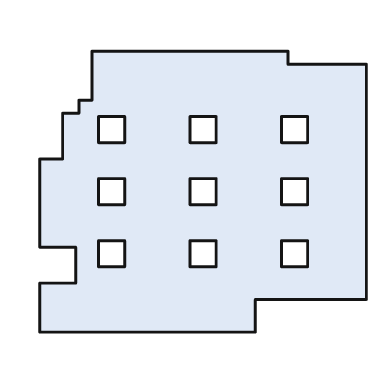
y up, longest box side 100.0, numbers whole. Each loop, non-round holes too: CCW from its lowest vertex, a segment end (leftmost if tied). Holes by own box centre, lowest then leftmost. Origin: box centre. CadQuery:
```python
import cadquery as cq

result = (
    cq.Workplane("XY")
    .moveTo(-50.0, -43.0)
    .lineTo(16.0, -43.0)
    .lineTo(16.0, -33.0)
    .lineTo(50.0, -33.0)
    .lineTo(50.0, 39.0)
    .lineTo(26.0, 39.0)
    .lineTo(26.0, 43.0)
    .lineTo(-34.0, 43.0)
    .lineTo(-34.0, 28.0)
    .lineTo(-38.0, 28.0)
    .lineTo(-38.0, 24.0)
    .lineTo(-43.0, 24.0)
    .lineTo(-43.0, 10.0)
    .lineTo(-50.0, 10.0)
    .lineTo(-50.0, -17.0)
    .lineTo(-39.0, -17.0)
    .lineTo(-39.0, -28.0)
    .lineTo(-50.0, -28.0)
    .close()
    .moveTo(-32.0, -23.0)
    .lineTo(-24.0, -23.0)
    .lineTo(-24.0, -15.0)
    .lineTo(-32.0, -15.0)
    .close()
    .moveTo(-4.0, -23.0)
    .lineTo(4.0, -23.0)
    .lineTo(4.0, -15.0)
    .lineTo(-4.0, -15.0)
    .close()
    .moveTo(24.0, -23.0)
    .lineTo(32.0, -23.0)
    .lineTo(32.0, -15.0)
    .lineTo(24.0, -15.0)
    .close()
    .moveTo(-32.0, -4.0)
    .lineTo(-24.0, -4.0)
    .lineTo(-24.0, 4.0)
    .lineTo(-32.0, 4.0)
    .close()
    .moveTo(-4.0, -4.0)
    .lineTo(4.0, -4.0)
    .lineTo(4.0, 4.0)
    .lineTo(-4.0, 4.0)
    .close()
    .moveTo(24.0, -4.0)
    .lineTo(32.0, -4.0)
    .lineTo(32.0, 4.0)
    .lineTo(24.0, 4.0)
    .close()
    .moveTo(-32.0, 15.0)
    .lineTo(-24.0, 15.0)
    .lineTo(-24.0, 23.0)
    .lineTo(-32.0, 23.0)
    .close()
    .moveTo(-4.0, 15.0)
    .lineTo(4.0, 15.0)
    .lineTo(4.0, 23.0)
    .lineTo(-4.0, 23.0)
    .close()
    .moveTo(24.0, 15.0)
    .lineTo(32.0, 15.0)
    .lineTo(32.0, 23.0)
    .lineTo(24.0, 23.0)
    .close()
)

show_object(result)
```